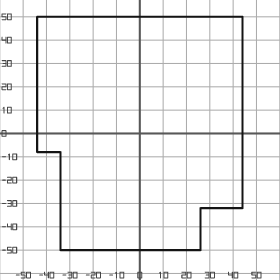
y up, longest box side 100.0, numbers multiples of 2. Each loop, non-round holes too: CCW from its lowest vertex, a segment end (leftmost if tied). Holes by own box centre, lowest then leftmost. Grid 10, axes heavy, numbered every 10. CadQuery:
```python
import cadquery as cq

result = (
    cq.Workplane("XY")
    .moveTo(-34.0, -50.0)
    .lineTo(26.0, -50.0)
    .lineTo(26.0, -32.0)
    .lineTo(44.0, -32.0)
    .lineTo(44.0, 50.0)
    .lineTo(-44.0, 50.0)
    .lineTo(-44.0, -8.0)
    .lineTo(-34.0, -8.0)
    .close()
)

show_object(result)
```